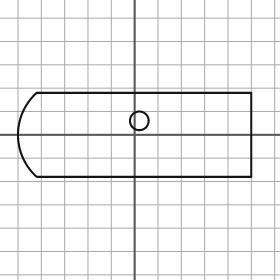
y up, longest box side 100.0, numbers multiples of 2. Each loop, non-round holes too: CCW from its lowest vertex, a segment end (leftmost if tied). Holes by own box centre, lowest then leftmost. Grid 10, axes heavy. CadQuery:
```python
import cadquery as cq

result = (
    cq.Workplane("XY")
    .moveTo(-42.0, -18.0)
    .lineTo(50.0, -18.0)
    .lineTo(50.0, 18.0)
    .lineTo(-42.0, 18.0)
    .threePointArc((-50.0, 0.0), (-42.0, -18.0))
    .close()
    .moveTo(2.0, 6.0)
    .circle(4.0)
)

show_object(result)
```